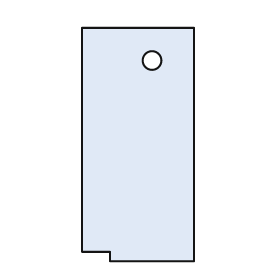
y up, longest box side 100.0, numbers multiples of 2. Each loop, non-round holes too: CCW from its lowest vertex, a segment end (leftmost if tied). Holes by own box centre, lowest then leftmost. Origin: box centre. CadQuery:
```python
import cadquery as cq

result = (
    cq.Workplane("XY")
    .moveTo(-12.0, -50.0)
    .lineTo(24.0, -50.0)
    .lineTo(24.0, 50.0)
    .lineTo(-24.0, 50.0)
    .lineTo(-24.0, -46.0)
    .lineTo(-12.0, -46.0)
    .close()
    .moveTo(6.0, 36.0)
    .circle(4.0)
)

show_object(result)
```